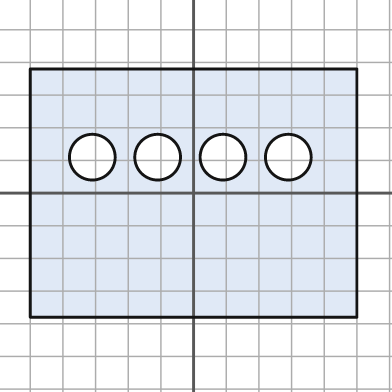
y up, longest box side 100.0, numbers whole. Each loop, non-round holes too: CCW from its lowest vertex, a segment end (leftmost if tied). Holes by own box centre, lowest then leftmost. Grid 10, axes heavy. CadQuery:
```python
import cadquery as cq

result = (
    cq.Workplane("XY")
    .moveTo(-50.0, -38.0)
    .lineTo(50.0, -38.0)
    .lineTo(50.0, 38.0)
    .lineTo(-50.0, 38.0)
    .close()
    .moveTo(-31.0, 11.0)
    .circle(7.0)
    .moveTo(-11.0, 11.0)
    .circle(7.0)
    .moveTo(9.0, 11.0)
    .circle(7.0)
    .moveTo(29.0, 11.0)
    .circle(7.0)
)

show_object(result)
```